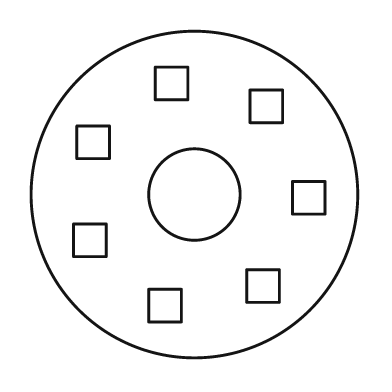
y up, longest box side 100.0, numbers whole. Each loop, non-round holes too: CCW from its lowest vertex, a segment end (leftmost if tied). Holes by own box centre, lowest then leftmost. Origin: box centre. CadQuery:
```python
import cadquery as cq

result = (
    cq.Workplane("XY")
    .moveTo(0.0, 0.0)
    .circle(50.0)
    .moveTo(-14.0, -39.0)
    .lineTo(-4.0, -39.0)
    .lineTo(-4.0, -29.0)
    .lineTo(-14.0, -29.0)
    .close()
    .moveTo(16.0, -33.0)
    .lineTo(26.0, -33.0)
    .lineTo(26.0, -23.0)
    .lineTo(16.0, -23.0)
    .close()
    .moveTo(-37.0, -19.0)
    .lineTo(-27.0, -19.0)
    .lineTo(-27.0, -9.0)
    .lineTo(-37.0, -9.0)
    .close()
    .moveTo(30.0, -6.0)
    .lineTo(40.0, -6.0)
    .lineTo(40.0, 4.0)
    .lineTo(30.0, 4.0)
    .close()
    .moveTo(0.0, 0.0)
    .circle(14.0)
    .moveTo(-36.0, 11.0)
    .lineTo(-26.0, 11.0)
    .lineTo(-26.0, 21.0)
    .lineTo(-36.0, 21.0)
    .close()
    .moveTo(17.0, 22.0)
    .lineTo(27.0, 22.0)
    .lineTo(27.0, 32.0)
    .lineTo(17.0, 32.0)
    .close()
    .moveTo(-12.0, 29.0)
    .lineTo(-2.0, 29.0)
    .lineTo(-2.0, 39.0)
    .lineTo(-12.0, 39.0)
    .close()
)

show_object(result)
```